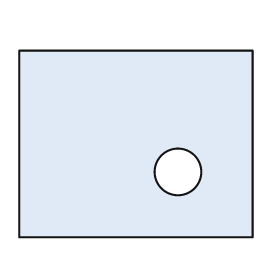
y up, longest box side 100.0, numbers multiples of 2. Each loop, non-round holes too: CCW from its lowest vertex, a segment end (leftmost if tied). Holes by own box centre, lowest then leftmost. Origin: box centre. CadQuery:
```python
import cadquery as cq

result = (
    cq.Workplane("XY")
    .moveTo(-50.0, -40.0)
    .lineTo(50.0, -40.0)
    .lineTo(50.0, 40.0)
    .lineTo(-50.0, 40.0)
    .close()
    .moveTo(18.0, -12.0)
    .circle(10.0)
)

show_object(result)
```